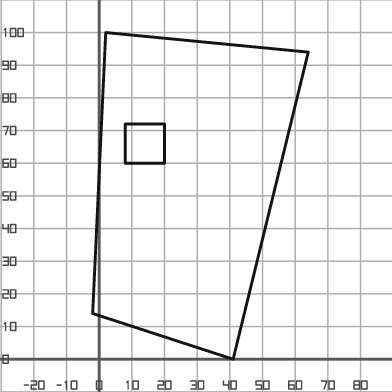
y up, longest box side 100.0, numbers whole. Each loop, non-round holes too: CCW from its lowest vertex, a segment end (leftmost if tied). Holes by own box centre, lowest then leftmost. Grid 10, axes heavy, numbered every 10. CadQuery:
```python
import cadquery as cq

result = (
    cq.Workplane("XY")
    .moveTo(41.0, 0.0)
    .lineTo(64.0, 94.0)
    .lineTo(2.0, 100.0)
    .lineTo(-2.0, 14.0)
    .close()
    .moveTo(8.0, 60.0)
    .lineTo(20.0, 60.0)
    .lineTo(20.0, 72.0)
    .lineTo(8.0, 72.0)
    .close()
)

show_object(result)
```